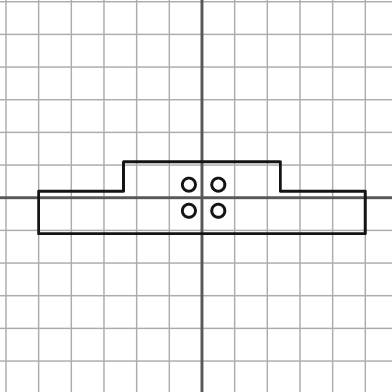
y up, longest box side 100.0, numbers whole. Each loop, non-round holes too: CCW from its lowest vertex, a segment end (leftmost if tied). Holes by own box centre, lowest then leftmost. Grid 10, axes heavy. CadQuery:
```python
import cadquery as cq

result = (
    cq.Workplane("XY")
    .moveTo(-50.0, -11.0)
    .lineTo(50.0, -11.0)
    .lineTo(50.0, 2.0)
    .lineTo(24.0, 2.0)
    .lineTo(24.0, 11.0)
    .lineTo(-24.0, 11.0)
    .lineTo(-24.0, 2.0)
    .lineTo(-50.0, 2.0)
    .close()
    .moveTo(-4.0, -4.0)
    .circle(2.0)
    .moveTo(5.0, -4.0)
    .circle(2.0)
    .moveTo(-4.0, 4.0)
    .circle(2.0)
    .moveTo(5.0, 4.0)
    .circle(2.0)
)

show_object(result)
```